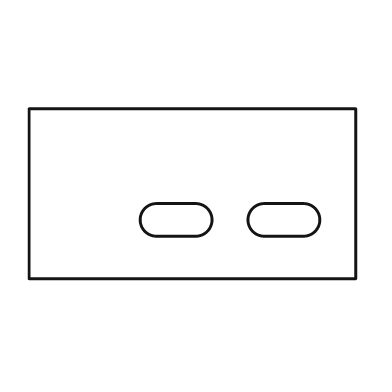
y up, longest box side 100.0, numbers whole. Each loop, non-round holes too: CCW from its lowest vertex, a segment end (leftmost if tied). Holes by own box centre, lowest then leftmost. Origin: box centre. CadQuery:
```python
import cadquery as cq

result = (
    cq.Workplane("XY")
    .moveTo(-50.0, -26.0)
    .lineTo(50.0, -26.0)
    .lineTo(50.0, 26.0)
    .lineTo(-50.0, 26.0)
    .close()
    .moveTo(-11.0, -13.0)
    .lineTo(1.0, -13.0)
    .threePointArc((6.0, -8.0), (1.0, -3.0))
    .lineTo(-11.0, -3.0)
    .threePointArc((-16.0, -8.0), (-11.0, -13.0))
    .close()
    .moveTo(22.0, -13.0)
    .lineTo(34.0, -13.0)
    .threePointArc((39.0, -8.0), (34.0, -3.0))
    .lineTo(22.0, -3.0)
    .threePointArc((17.0, -8.0), (22.0, -13.0))
    .close()
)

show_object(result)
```